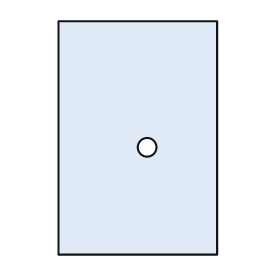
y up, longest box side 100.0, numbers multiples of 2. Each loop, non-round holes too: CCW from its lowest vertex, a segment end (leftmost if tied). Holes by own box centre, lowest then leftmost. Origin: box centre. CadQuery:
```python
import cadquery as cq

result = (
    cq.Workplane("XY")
    .moveTo(-34.0, -50.0)
    .lineTo(34.0, -50.0)
    .lineTo(34.0, 50.0)
    .lineTo(-34.0, 50.0)
    .close()
    .moveTo(4.0, -4.0)
    .circle(4.0)
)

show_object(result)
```